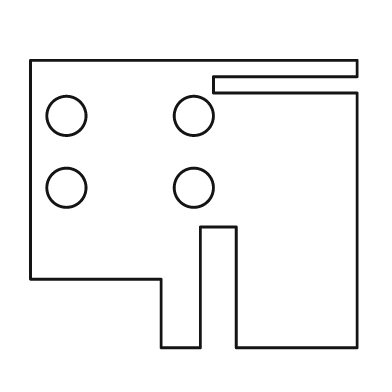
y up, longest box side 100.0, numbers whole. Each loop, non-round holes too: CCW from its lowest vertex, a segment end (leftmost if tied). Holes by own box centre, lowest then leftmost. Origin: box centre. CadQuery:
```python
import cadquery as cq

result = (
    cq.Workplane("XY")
    .moveTo(-10.0, -44.0)
    .lineTo(2.0, -44.0)
    .lineTo(2.0, -7.0)
    .lineTo(13.0, -7.0)
    .lineTo(13.0, -44.0)
    .lineTo(50.0, -44.0)
    .lineTo(50.0, 34.0)
    .lineTo(6.0, 34.0)
    .lineTo(6.0, 39.0)
    .lineTo(50.0, 39.0)
    .lineTo(50.0, 44.0)
    .lineTo(-50.0, 44.0)
    .lineTo(-50.0, -23.0)
    .lineTo(-10.0, -23.0)
    .close()
    .moveTo(-39.0, 5.0)
    .circle(6.0)
    .moveTo(0.0, 5.0)
    .circle(6.0)
    .moveTo(-39.0, 27.0)
    .circle(6.0)
    .moveTo(0.0, 27.0)
    .circle(6.0)
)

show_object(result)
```